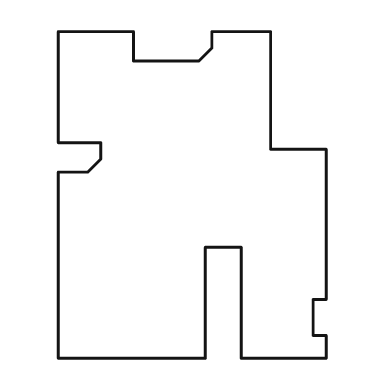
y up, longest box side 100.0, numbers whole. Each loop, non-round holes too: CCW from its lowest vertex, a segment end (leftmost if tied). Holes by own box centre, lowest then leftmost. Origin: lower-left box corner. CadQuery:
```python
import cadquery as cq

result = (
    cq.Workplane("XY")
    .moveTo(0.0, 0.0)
    .lineTo(45.0, 0.0)
    .lineTo(45.0, 34.0)
    .lineTo(56.0, 34.0)
    .lineTo(56.0, 0.0)
    .lineTo(82.0, 0.0)
    .lineTo(82.0, 7.0)
    .lineTo(78.0, 7.0)
    .lineTo(78.0, 18.0)
    .lineTo(82.0, 18.0)
    .lineTo(82.0, 64.0)
    .lineTo(65.0, 64.0)
    .lineTo(65.0, 100.0)
    .lineTo(47.0, 100.0)
    .lineTo(47.0, 95.0)
    .lineTo(43.0, 91.0)
    .lineTo(23.0, 91.0)
    .lineTo(23.0, 100.0)
    .lineTo(0.0, 100.0)
    .lineTo(0.0, 66.0)
    .lineTo(13.0, 66.0)
    .lineTo(13.0, 61.0)
    .lineTo(9.0, 57.0)
    .lineTo(0.0, 57.0)
    .close()
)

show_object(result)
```